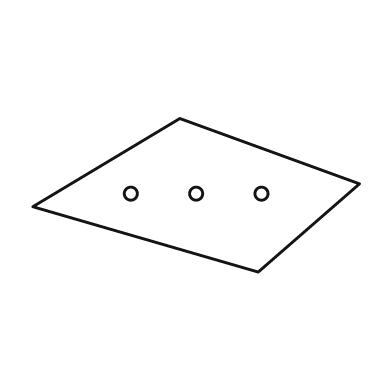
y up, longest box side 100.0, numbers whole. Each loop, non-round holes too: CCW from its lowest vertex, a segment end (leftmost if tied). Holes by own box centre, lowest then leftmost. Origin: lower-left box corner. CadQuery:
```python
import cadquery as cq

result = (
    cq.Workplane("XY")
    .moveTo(69.0, 0.0)
    .lineTo(100.0, 27.0)
    .lineTo(45.0, 47.0)
    .lineTo(0.0, 20.0)
    .close()
    .moveTo(30.0, 24.0)
    .circle(2.0)
    .moveTo(50.0, 24.0)
    .circle(2.0)
    .moveTo(70.0, 24.0)
    .circle(2.0)
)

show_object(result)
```